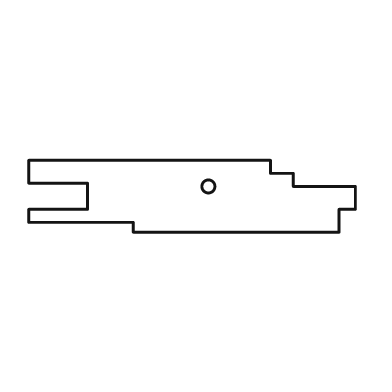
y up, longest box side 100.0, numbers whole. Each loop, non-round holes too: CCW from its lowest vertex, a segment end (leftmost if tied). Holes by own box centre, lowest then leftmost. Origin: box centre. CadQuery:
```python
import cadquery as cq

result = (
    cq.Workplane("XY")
    .moveTo(-18.0, -11.0)
    .lineTo(45.0, -11.0)
    .lineTo(45.0, -4.0)
    .lineTo(50.0, -4.0)
    .lineTo(50.0, 3.0)
    .lineTo(31.0, 3.0)
    .lineTo(31.0, 7.0)
    .lineTo(24.0, 7.0)
    .lineTo(24.0, 11.0)
    .lineTo(-50.0, 11.0)
    .lineTo(-50.0, 4.0)
    .lineTo(-32.0, 4.0)
    .lineTo(-32.0, -4.0)
    .lineTo(-50.0, -4.0)
    .lineTo(-50.0, -8.0)
    .lineTo(-18.0, -8.0)
    .close()
    .moveTo(5.0, 3.0)
    .circle(2.0)
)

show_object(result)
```